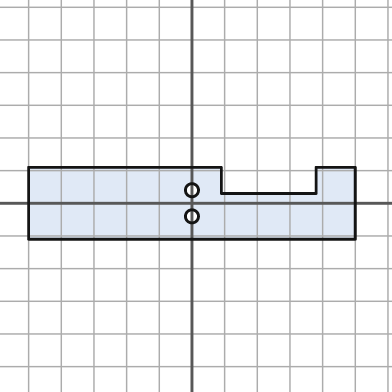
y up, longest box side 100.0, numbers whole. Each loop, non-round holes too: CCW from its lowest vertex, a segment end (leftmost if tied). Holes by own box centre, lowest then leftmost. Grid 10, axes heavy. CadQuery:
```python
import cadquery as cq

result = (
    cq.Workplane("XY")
    .moveTo(-50.0, -11.0)
    .lineTo(50.0, -11.0)
    .lineTo(50.0, 11.0)
    .lineTo(38.0, 11.0)
    .lineTo(38.0, 3.0)
    .lineTo(9.0, 3.0)
    .lineTo(9.0, 11.0)
    .lineTo(-50.0, 11.0)
    .close()
    .moveTo(0.0, -4.0)
    .circle(2.0)
    .moveTo(0.0, 4.0)
    .circle(2.0)
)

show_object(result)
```